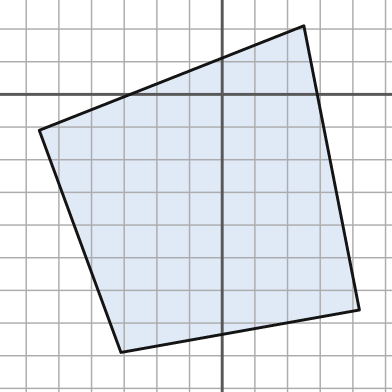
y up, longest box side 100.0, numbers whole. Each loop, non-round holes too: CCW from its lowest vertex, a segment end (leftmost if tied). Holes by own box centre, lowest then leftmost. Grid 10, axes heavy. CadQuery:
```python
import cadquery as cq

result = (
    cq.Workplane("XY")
    .moveTo(-31.0, -79.0)
    .lineTo(42.0, -66.0)
    .lineTo(25.0, 21.0)
    .lineTo(-56.0, -11.0)
    .close()
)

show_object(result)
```